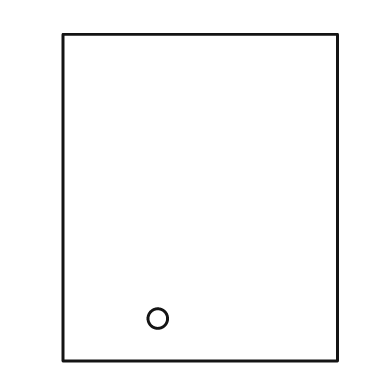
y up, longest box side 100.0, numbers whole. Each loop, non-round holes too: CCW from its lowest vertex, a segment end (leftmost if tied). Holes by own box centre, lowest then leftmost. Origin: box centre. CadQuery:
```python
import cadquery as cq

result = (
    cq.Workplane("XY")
    .moveTo(-42.0, -50.0)
    .lineTo(42.0, -50.0)
    .lineTo(42.0, 50.0)
    .lineTo(-42.0, 50.0)
    .close()
    .moveTo(-13.0, -37.0)
    .circle(3.0)
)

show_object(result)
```